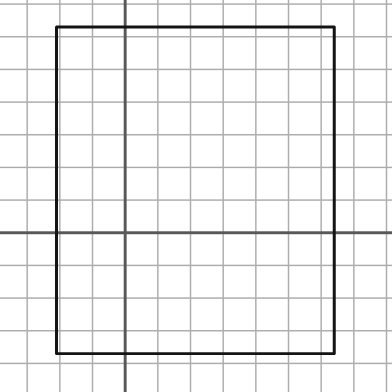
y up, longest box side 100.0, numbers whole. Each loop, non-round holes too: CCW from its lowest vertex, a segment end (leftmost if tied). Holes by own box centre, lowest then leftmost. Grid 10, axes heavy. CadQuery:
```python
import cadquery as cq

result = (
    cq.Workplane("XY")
    .moveTo(-21.0, -37.0)
    .lineTo(64.0, -37.0)
    .lineTo(64.0, 63.0)
    .lineTo(-21.0, 63.0)
    .close()
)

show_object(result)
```